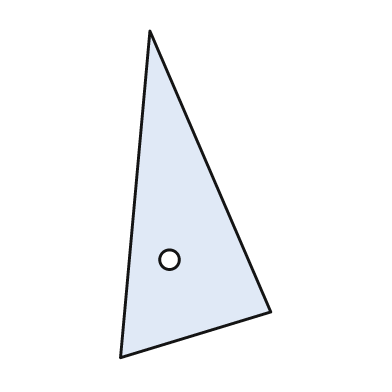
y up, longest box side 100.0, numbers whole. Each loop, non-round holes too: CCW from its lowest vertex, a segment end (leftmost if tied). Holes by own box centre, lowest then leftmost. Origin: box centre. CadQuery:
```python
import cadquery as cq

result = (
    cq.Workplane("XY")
    .moveTo(-23.0, -50.0)
    .lineTo(23.0, -36.0)
    .lineTo(-14.0, 50.0)
    .close()
    .moveTo(-8.0, -20.0)
    .circle(3.0)
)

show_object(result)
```